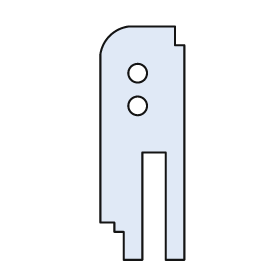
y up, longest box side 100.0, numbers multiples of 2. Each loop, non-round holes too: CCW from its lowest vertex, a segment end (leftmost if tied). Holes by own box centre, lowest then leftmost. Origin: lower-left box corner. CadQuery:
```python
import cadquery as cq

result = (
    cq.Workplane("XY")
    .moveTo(10.0, 0.0)
    .lineTo(18.0, 0.0)
    .lineTo(18.0, 46.0)
    .lineTo(28.0, 46.0)
    .lineTo(28.0, 0.0)
    .lineTo(36.0, 0.0)
    .lineTo(36.0, 92.0)
    .lineTo(32.0, 92.0)
    .lineTo(32.0, 100.0)
    .lineTo(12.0, 100.0)
    .threePointArc((4.0, 96.0), (0.0, 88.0))
    .lineTo(0.0, 16.0)
    .lineTo(6.0, 16.0)
    .lineTo(6.0, 12.0)
    .lineTo(10.0, 12.0)
    .close()
    .moveTo(16.0, 66.0)
    .circle(4.0)
    .moveTo(16.0, 80.0)
    .circle(4.0)
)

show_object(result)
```